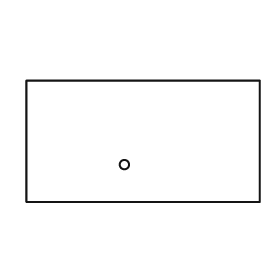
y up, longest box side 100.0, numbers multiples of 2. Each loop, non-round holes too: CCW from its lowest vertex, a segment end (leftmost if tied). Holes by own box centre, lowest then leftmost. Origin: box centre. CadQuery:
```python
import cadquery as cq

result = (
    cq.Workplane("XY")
    .moveTo(-50.0, -26.0)
    .lineTo(50.0, -26.0)
    .lineTo(50.0, 26.0)
    .lineTo(-50.0, 26.0)
    .close()
    .moveTo(-8.0, -10.0)
    .circle(2.0)
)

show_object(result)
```